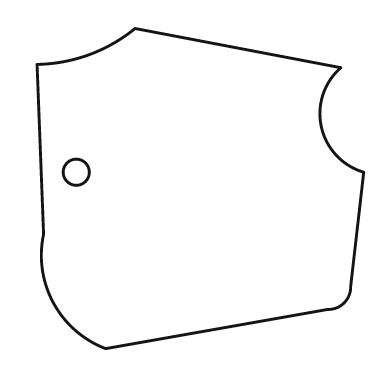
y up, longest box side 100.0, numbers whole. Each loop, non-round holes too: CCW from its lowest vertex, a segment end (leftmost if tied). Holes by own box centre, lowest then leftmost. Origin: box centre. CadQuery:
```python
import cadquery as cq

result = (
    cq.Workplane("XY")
    .moveTo(-29.0, -49.0)
    .lineTo(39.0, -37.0)
    .threePointArc((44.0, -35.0), (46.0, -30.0))
    .lineTo(50.0, 5.0)
    .threePointArc((37.0, 19.0), (43.0, 37.0))
    .lineTo(-20.0, 49.0)
    .threePointArc((-34.0, 41.0), (-50.0, 38.0))
    .lineTo(-48.0, -14.0)
    .threePointArc((-45.0, -35.0), (-29.0, -49.0))
    .close()
    .moveTo(-38.0, 5.0)
    .circle(4.0)
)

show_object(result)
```